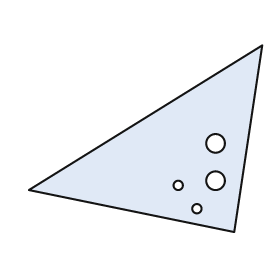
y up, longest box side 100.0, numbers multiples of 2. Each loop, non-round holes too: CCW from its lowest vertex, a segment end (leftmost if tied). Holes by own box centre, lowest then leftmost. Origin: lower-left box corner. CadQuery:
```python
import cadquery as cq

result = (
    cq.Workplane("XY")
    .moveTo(88.0, 0.0)
    .lineTo(100.0, 80.0)
    .lineTo(0.0, 18.0)
    .close()
    .moveTo(72.0, 10.0)
    .circle(2.0)
    .moveTo(64.0, 20.0)
    .circle(2.0)
    .moveTo(80.0, 22.0)
    .circle(4.0)
    .moveTo(80.0, 38.0)
    .circle(4.0)
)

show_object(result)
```